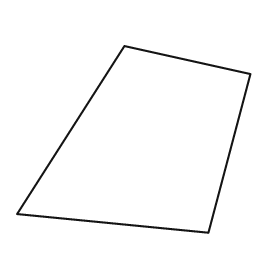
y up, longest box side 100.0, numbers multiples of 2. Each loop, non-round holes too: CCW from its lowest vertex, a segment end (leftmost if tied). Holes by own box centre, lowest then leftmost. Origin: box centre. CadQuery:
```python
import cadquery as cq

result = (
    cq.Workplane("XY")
    .moveTo(32.0, -40.0)
    .lineTo(50.0, 28.0)
    .lineTo(-4.0, 40.0)
    .lineTo(-50.0, -32.0)
    .close()
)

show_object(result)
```